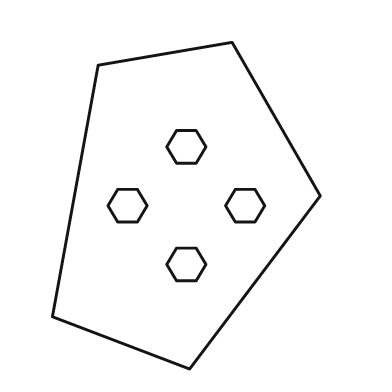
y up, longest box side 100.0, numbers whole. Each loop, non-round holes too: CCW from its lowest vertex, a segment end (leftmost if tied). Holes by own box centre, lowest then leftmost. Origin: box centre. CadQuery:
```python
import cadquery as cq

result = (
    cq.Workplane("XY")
    .moveTo(1.0, -50.0)
    .lineTo(41.0, 3.0)
    .lineTo(14.0, 50.0)
    .lineTo(-27.0, 43.0)
    .lineTo(-41.0, -34.0)
    .close()
    .moveTo(-3.0, -23.0)
    .lineTo(3.0, -23.0)
    .lineTo(6.0, -18.0)
    .lineTo(3.0, -13.0)
    .lineTo(-3.0, -13.0)
    .lineTo(-6.0, -18.0)
    .close()
    .moveTo(-21.0, -5.0)
    .lineTo(-15.0, -5.0)
    .lineTo(-12.0, 0.0)
    .lineTo(-15.0, 5.0)
    .lineTo(-21.0, 5.0)
    .lineTo(-24.0, 0.0)
    .close()
    .moveTo(15.0, -5.0)
    .lineTo(21.0, -5.0)
    .lineTo(24.0, 0.0)
    .lineTo(21.0, 5.0)
    .lineTo(15.0, 5.0)
    .lineTo(12.0, 0.0)
    .close()
    .moveTo(-3.0, 13.0)
    .lineTo(3.0, 13.0)
    .lineTo(6.0, 18.0)
    .lineTo(3.0, 23.0)
    .lineTo(-3.0, 23.0)
    .lineTo(-6.0, 18.0)
    .close()
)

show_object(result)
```